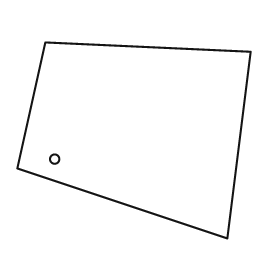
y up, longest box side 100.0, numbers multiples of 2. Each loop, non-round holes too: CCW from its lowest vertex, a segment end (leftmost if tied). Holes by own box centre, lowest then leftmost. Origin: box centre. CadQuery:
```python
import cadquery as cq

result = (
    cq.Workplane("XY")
    .moveTo(40.0, -42.0)
    .lineTo(50.0, 38.0)
    .lineTo(-38.0, 42.0)
    .lineTo(-50.0, -12.0)
    .close()
    .moveTo(-34.0, -8.0)
    .circle(2.0)
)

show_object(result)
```